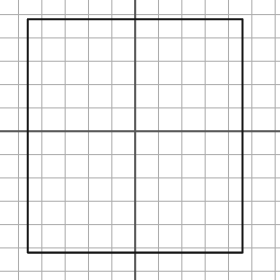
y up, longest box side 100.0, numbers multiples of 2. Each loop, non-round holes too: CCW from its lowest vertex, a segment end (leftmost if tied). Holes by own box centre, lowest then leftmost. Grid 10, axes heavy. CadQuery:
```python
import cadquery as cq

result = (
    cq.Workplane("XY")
    .moveTo(-46.0, -52.0)
    .lineTo(46.0, -52.0)
    .lineTo(46.0, 48.0)
    .lineTo(-46.0, 48.0)
    .close()
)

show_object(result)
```